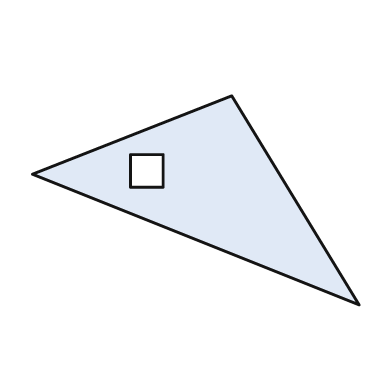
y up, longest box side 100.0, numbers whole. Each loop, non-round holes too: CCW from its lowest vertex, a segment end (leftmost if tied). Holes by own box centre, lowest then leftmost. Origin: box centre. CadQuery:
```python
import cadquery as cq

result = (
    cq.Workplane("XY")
    .moveTo(50.0, -32.0)
    .lineTo(11.0, 32.0)
    .lineTo(-50.0, 8.0)
    .close()
    .moveTo(-20.0, 4.0)
    .lineTo(-10.0, 4.0)
    .lineTo(-10.0, 14.0)
    .lineTo(-20.0, 14.0)
    .close()
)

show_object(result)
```